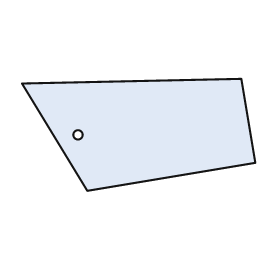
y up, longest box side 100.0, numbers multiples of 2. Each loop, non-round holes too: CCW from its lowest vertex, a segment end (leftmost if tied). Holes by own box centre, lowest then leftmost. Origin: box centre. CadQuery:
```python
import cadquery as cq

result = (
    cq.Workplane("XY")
    .moveTo(-22.0, -24.0)
    .lineTo(50.0, -12.0)
    .lineTo(44.0, 24.0)
    .lineTo(-50.0, 22.0)
    .close()
    .moveTo(-26.0, 0.0)
    .circle(2.0)
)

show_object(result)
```